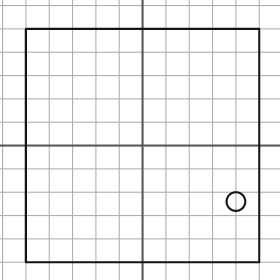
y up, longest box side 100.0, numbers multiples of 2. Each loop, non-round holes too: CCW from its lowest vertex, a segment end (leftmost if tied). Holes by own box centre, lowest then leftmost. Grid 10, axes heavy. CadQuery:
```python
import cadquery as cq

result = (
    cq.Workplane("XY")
    .moveTo(-50.0, -50.0)
    .lineTo(50.0, -50.0)
    .lineTo(50.0, 50.0)
    .lineTo(-50.0, 50.0)
    .close()
    .moveTo(40.0, -24.0)
    .circle(4.0)
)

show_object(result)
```